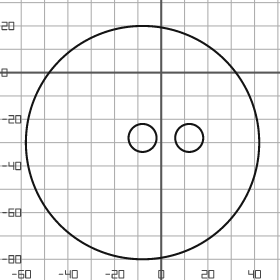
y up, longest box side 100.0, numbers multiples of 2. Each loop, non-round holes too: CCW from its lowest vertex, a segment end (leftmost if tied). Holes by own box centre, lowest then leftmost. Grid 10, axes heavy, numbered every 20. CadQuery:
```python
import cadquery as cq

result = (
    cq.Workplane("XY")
    .moveTo(-8.0, -30.0)
    .circle(50.0)
    .moveTo(-8.0, -28.0)
    .circle(6.0)
    .moveTo(12.0, -28.0)
    .circle(6.0)
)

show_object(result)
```